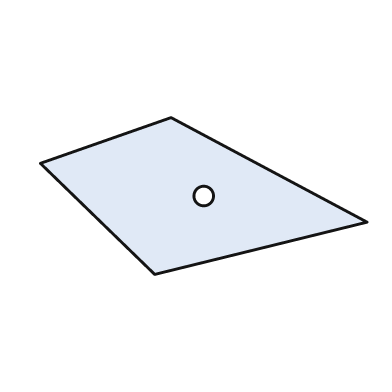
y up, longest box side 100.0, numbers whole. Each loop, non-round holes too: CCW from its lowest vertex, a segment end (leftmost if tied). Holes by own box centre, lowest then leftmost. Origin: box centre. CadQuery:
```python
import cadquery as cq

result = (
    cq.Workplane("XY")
    .moveTo(-15.0, -24.0)
    .lineTo(50.0, -8.0)
    .lineTo(-10.0, 24.0)
    .lineTo(-50.0, 10.0)
    .close()
    .moveTo(0.0, 0.0)
    .circle(3.0)
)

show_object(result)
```